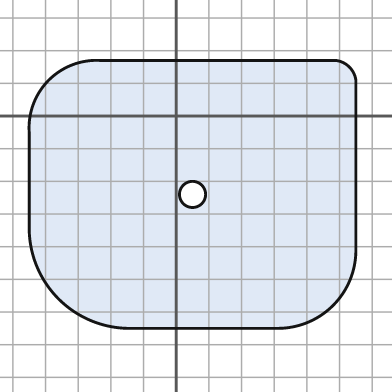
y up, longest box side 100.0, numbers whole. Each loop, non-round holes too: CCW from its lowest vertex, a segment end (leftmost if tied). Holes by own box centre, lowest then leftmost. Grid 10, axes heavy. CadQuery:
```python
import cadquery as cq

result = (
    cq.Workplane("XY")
    .moveTo(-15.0, -65.0)
    .lineTo(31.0, -65.0)
    .threePointArc((48.0, -58.0), (55.0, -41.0))
    .lineTo(55.0, 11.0)
    .threePointArc((53.0, 15.0), (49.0, 17.0))
    .lineTo(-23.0, 17.0)
    .threePointArc((-39.0, 11.0), (-45.0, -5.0))
    .lineTo(-45.0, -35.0)
    .threePointArc((-36.0, -56.0), (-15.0, -65.0))
    .close()
    .moveTo(5.0, -24.0)
    .circle(4.0)
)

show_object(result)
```